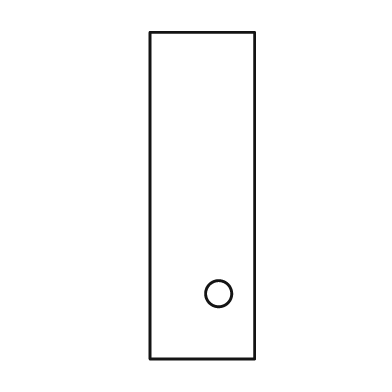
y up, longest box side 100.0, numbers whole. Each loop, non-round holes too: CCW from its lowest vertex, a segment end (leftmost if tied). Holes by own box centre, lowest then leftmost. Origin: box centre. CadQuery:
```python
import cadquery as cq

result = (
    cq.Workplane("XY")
    .moveTo(-16.0, -50.0)
    .lineTo(16.0, -50.0)
    .lineTo(16.0, 50.0)
    .lineTo(-16.0, 50.0)
    .close()
    .moveTo(5.0, -30.0)
    .circle(4.0)
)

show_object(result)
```